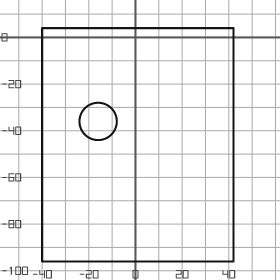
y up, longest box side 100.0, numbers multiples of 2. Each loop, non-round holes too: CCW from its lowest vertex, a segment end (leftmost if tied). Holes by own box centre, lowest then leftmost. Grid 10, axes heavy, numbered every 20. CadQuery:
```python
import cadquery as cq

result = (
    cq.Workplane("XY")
    .moveTo(-40.0, -96.0)
    .lineTo(42.0, -96.0)
    .lineTo(42.0, 4.0)
    .lineTo(-40.0, 4.0)
    .close()
    .moveTo(-16.0, -36.0)
    .circle(8.0)
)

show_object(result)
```